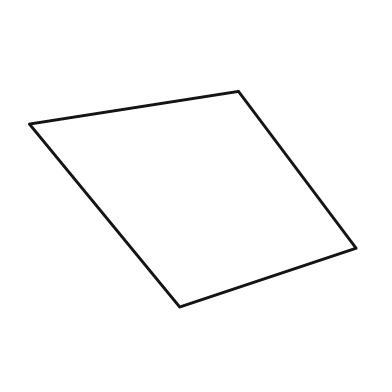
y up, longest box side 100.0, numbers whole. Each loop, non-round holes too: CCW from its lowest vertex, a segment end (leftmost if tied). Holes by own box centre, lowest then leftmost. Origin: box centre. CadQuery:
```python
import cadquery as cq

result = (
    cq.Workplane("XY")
    .moveTo(-4.0, -33.0)
    .lineTo(50.0, -15.0)
    .lineTo(14.0, 33.0)
    .lineTo(-50.0, 23.0)
    .close()
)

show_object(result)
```